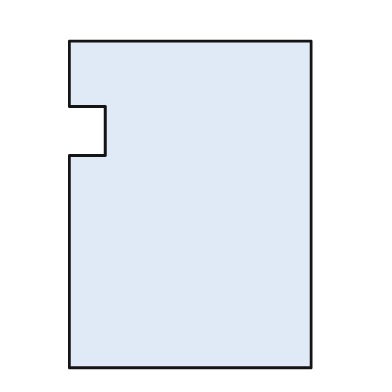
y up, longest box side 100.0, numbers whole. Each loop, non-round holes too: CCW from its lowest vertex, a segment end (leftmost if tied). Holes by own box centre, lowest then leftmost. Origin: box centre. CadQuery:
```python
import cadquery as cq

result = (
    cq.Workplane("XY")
    .moveTo(-37.0, -50.0)
    .lineTo(37.0, -50.0)
    .lineTo(37.0, 50.0)
    .lineTo(-37.0, 50.0)
    .lineTo(-37.0, 30.0)
    .lineTo(-26.0, 30.0)
    .lineTo(-26.0, 15.0)
    .lineTo(-37.0, 15.0)
    .close()
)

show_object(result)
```